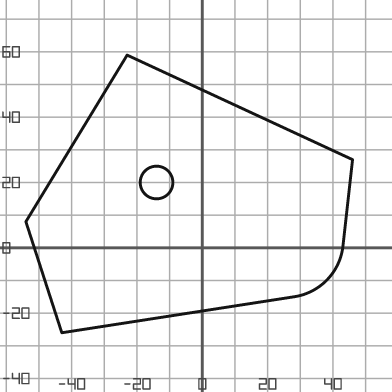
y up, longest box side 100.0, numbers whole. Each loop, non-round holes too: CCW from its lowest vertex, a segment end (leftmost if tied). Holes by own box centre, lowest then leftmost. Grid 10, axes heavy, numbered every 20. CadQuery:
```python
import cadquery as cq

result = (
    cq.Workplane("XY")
    .moveTo(-43.0, -26.0)
    .lineTo(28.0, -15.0)
    .threePointArc((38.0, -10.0), (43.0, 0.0))
    .lineTo(46.0, 27.0)
    .lineTo(-23.0, 59.0)
    .lineTo(-54.0, 8.0)
    .close()
    .moveTo(-14.0, 20.0)
    .circle(5.0)
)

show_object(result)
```